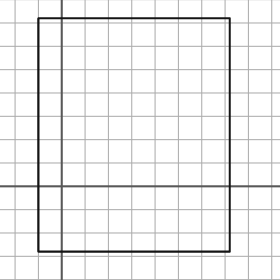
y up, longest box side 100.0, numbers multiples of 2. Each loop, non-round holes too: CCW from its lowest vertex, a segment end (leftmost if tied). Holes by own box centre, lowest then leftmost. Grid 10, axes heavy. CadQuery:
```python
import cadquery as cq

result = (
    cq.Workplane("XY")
    .moveTo(-10.0, -28.0)
    .lineTo(72.0, -28.0)
    .lineTo(72.0, 72.0)
    .lineTo(-10.0, 72.0)
    .close()
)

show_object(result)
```